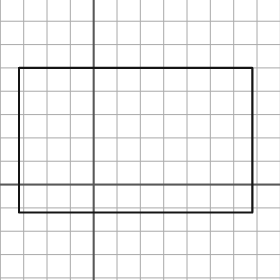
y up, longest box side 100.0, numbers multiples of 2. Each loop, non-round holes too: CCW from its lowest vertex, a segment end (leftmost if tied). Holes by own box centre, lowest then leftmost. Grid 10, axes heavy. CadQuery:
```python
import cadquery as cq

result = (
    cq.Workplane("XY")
    .moveTo(-32.0, -12.0)
    .lineTo(68.0, -12.0)
    .lineTo(68.0, 50.0)
    .lineTo(-32.0, 50.0)
    .close()
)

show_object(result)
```